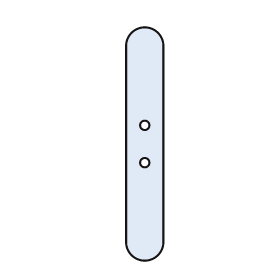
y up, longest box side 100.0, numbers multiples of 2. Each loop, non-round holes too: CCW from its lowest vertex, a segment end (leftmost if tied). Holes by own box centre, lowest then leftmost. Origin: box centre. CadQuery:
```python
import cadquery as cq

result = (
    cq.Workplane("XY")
    .moveTo(-8.0, -42.0)
    .threePointArc((0.0, -50.0), (8.0, -42.0))
    .lineTo(8.0, 42.0)
    .threePointArc((0.0, 50.0), (-8.0, 42.0))
    .close()
    .moveTo(0.0, -8.0)
    .circle(2.0)
    .moveTo(0.0, 8.0)
    .circle(2.0)
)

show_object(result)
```